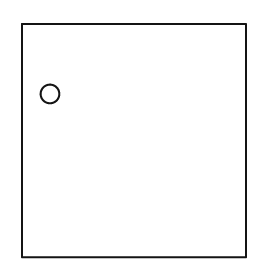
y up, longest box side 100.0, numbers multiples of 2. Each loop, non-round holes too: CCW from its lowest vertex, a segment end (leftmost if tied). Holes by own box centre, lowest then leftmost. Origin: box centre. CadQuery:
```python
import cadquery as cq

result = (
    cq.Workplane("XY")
    .moveTo(-48.0, -50.0)
    .lineTo(48.0, -50.0)
    .lineTo(48.0, 50.0)
    .lineTo(-48.0, 50.0)
    .close()
    .moveTo(-36.0, 20.0)
    .circle(4.0)
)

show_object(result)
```